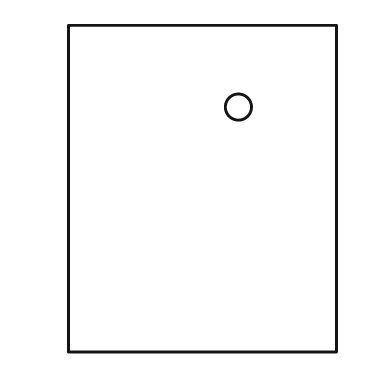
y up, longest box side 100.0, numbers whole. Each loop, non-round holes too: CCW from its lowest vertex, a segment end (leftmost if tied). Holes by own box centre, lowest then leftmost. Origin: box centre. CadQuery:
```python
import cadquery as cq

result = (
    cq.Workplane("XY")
    .moveTo(-41.0, -50.0)
    .lineTo(41.0, -50.0)
    .lineTo(41.0, 50.0)
    .lineTo(-41.0, 50.0)
    .close()
    .moveTo(11.0, 25.0)
    .circle(4.0)
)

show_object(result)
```